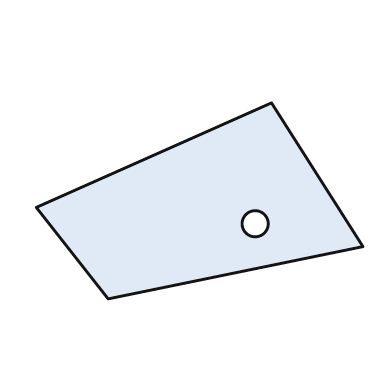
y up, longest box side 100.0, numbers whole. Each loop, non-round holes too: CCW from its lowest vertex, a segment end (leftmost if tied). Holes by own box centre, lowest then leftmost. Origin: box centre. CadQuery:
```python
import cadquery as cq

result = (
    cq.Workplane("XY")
    .moveTo(-28.0, -30.0)
    .lineTo(50.0, -14.0)
    .lineTo(22.0, 30.0)
    .lineTo(-50.0, -2.0)
    .close()
    .moveTo(17.0, -7.0)
    .circle(4.0)
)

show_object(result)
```